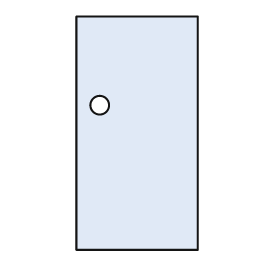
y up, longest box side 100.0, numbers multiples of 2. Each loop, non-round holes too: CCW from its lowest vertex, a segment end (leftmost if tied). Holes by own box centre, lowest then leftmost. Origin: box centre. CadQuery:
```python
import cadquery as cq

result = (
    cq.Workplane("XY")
    .moveTo(-26.0, -50.0)
    .lineTo(26.0, -50.0)
    .lineTo(26.0, 50.0)
    .lineTo(-26.0, 50.0)
    .close()
    .moveTo(-16.0, 12.0)
    .circle(4.0)
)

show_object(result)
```